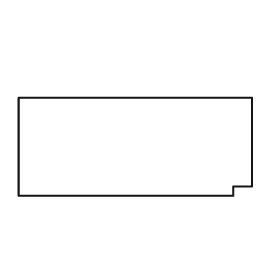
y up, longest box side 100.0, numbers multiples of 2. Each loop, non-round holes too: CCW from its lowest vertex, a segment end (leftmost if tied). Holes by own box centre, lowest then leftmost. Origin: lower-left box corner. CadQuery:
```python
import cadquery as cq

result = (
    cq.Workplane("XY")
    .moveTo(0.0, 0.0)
    .lineTo(92.0, 0.0)
    .lineTo(92.0, 4.0)
    .lineTo(100.0, 4.0)
    .lineTo(100.0, 42.0)
    .lineTo(0.0, 42.0)
    .close()
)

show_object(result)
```